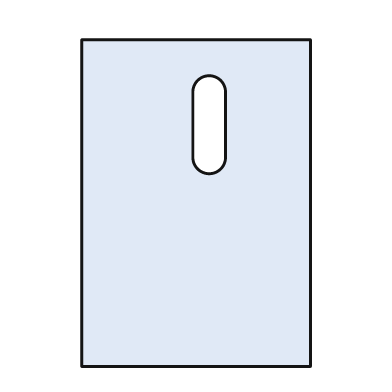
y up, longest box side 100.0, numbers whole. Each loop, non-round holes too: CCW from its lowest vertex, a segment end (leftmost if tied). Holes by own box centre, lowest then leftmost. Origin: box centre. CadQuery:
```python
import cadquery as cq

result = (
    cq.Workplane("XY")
    .moveTo(-35.0, -50.0)
    .lineTo(35.0, -50.0)
    .lineTo(35.0, 50.0)
    .lineTo(-35.0, 50.0)
    .close()
    .moveTo(-1.0, 14.0)
    .threePointArc((4.0, 9.0), (9.0, 14.0))
    .lineTo(9.0, 34.0)
    .threePointArc((4.0, 39.0), (-1.0, 34.0))
    .close()
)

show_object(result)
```